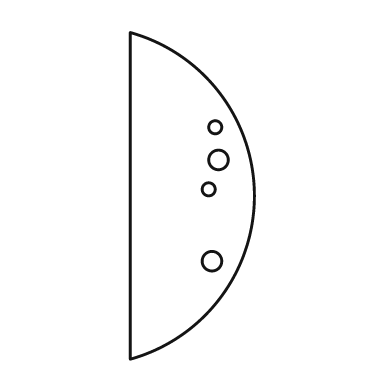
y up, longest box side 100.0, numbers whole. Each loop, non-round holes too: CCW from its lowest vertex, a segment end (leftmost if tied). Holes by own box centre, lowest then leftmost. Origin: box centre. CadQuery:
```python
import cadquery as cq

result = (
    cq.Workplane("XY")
    .moveTo(-19.0, -50.0)
    .threePointArc((19.0, 0.0), (-19.0, 50.0))
    .close()
    .moveTo(6.0, -20.0)
    .circle(3.0)
    .moveTo(5.0, 2.0)
    .circle(2.0)
    .moveTo(8.0, 11.0)
    .circle(3.0)
    .moveTo(7.0, 21.0)
    .circle(2.0)
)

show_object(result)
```